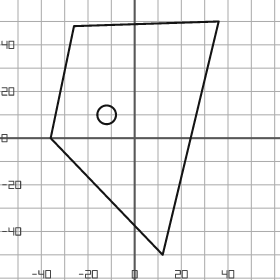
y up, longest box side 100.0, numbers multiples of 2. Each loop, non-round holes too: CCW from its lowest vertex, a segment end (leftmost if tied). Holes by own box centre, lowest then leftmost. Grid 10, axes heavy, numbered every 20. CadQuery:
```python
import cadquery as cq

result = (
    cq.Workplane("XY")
    .moveTo(12.0, -50.0)
    .lineTo(36.0, 50.0)
    .lineTo(-26.0, 48.0)
    .lineTo(-36.0, 0.0)
    .close()
    .moveTo(-12.0, 10.0)
    .circle(4.0)
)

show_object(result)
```